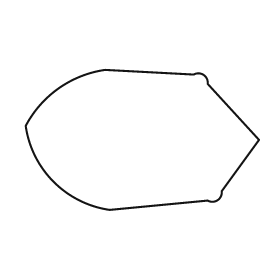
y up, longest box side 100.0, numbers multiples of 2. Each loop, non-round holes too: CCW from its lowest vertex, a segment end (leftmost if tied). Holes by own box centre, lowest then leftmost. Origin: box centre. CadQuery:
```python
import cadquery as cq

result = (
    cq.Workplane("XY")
    .moveTo(-14.0, -30.0)
    .lineTo(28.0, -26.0)
    .threePointArc((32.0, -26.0), (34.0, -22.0))
    .lineTo(50.0, 0.0)
    .lineTo(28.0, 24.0)
    .threePointArc((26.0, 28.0), (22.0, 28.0))
    .lineTo(-16.0, 30.0)
    .threePointArc((-36.0, 22.0), (-50.0, 6.0))
    .threePointArc((-38.0, -18.0), (-14.0, -30.0))
    .close()
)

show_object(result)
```